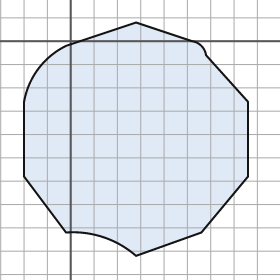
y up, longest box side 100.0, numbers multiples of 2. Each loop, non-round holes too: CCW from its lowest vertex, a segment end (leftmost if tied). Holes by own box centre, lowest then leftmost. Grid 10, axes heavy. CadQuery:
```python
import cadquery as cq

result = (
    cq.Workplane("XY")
    .moveTo(28.0, -92.0)
    .lineTo(56.0, -82.0)
    .lineTo(76.0, -58.0)
    .lineTo(76.0, -26.0)
    .lineTo(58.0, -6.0)
    .threePointArc((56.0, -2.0), (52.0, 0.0))
    .lineTo(28.0, 8.0)
    .lineTo(-2.0, -2.0)
    .threePointArc((-14.0, -12.0), (-20.0, -26.0))
    .lineTo(-20.0, -58.0)
    .lineTo(-2.0, -82.0)
    .threePointArc((14.0, -84.0), (28.0, -92.0))
    .close()
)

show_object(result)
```